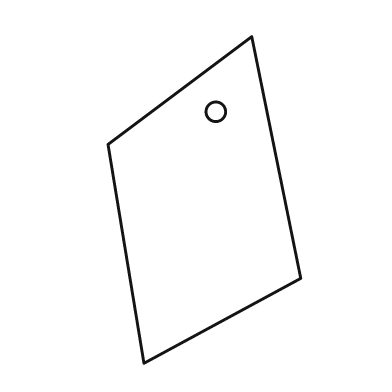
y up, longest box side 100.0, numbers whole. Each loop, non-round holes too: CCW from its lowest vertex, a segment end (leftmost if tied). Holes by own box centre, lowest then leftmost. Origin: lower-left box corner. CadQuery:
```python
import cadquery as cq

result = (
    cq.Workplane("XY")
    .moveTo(11.0, 0.0)
    .lineTo(59.0, 26.0)
    .lineTo(44.0, 100.0)
    .lineTo(0.0, 67.0)
    .close()
    .moveTo(33.0, 77.0)
    .circle(3.0)
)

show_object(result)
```